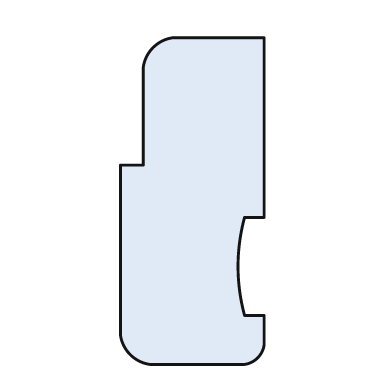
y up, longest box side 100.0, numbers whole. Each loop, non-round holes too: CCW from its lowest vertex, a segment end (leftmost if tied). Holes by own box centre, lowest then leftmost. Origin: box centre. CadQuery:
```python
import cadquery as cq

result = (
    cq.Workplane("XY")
    .moveTo(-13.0, -50.0)
    .lineTo(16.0, -50.0)
    .threePointArc((20.0, -48.0), (22.0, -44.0))
    .lineTo(22.0, -35.0)
    .lineTo(16.0, -35.0)
    .threePointArc((14.0, -20.0), (16.0, -5.0))
    .lineTo(22.0, -5.0)
    .lineTo(22.0, 50.0)
    .lineTo(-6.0, 50.0)
    .threePointArc((-12.0, 47.0), (-15.0, 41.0))
    .lineTo(-15.0, 11.0)
    .lineTo(-22.0, 11.0)
    .lineTo(-22.0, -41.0)
    .threePointArc((-19.0, -47.0), (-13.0, -50.0))
    .close()
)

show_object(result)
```